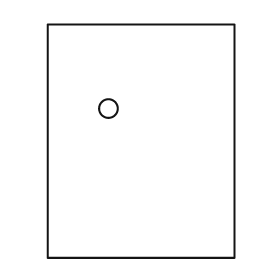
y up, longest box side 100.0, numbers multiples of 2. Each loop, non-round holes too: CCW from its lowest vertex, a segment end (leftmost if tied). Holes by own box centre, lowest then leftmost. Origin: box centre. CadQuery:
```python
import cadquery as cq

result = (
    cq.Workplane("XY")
    .moveTo(-40.0, -50.0)
    .lineTo(40.0, -50.0)
    .lineTo(40.0, 50.0)
    .lineTo(-40.0, 50.0)
    .close()
    .moveTo(-14.0, 14.0)
    .circle(4.0)
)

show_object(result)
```